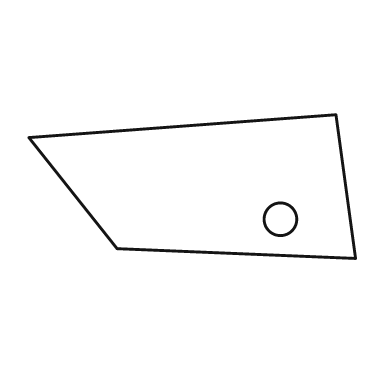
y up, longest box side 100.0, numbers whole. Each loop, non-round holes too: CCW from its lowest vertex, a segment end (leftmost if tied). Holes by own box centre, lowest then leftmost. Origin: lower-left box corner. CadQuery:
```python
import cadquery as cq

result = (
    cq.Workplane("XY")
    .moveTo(100.0, 0.0)
    .lineTo(94.0, 44.0)
    .lineTo(0.0, 37.0)
    .lineTo(27.0, 3.0)
    .close()
    .moveTo(77.0, 12.0)
    .circle(5.0)
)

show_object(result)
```